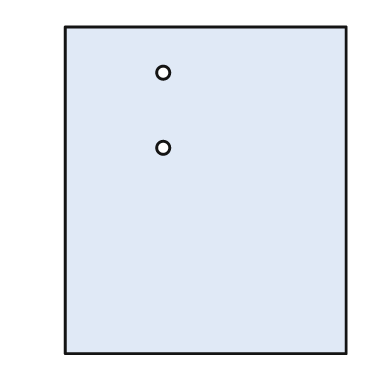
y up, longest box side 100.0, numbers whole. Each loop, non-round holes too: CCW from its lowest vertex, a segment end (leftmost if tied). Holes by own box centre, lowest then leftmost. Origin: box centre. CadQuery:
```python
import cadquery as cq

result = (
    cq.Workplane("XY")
    .moveTo(-43.0, -50.0)
    .lineTo(43.0, -50.0)
    .lineTo(43.0, 50.0)
    .lineTo(-43.0, 50.0)
    .close()
    .moveTo(-13.0, 13.0)
    .circle(2.0)
    .moveTo(-13.0, 36.0)
    .circle(2.0)
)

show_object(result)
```